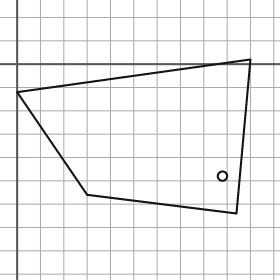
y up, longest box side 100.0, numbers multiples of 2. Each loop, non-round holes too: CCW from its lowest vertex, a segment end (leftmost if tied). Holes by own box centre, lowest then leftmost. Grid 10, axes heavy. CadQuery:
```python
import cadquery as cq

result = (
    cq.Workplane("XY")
    .moveTo(94.0, -64.0)
    .lineTo(100.0, 2.0)
    .lineTo(0.0, -12.0)
    .lineTo(30.0, -56.0)
    .close()
    .moveTo(88.0, -48.0)
    .circle(2.0)
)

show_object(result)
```